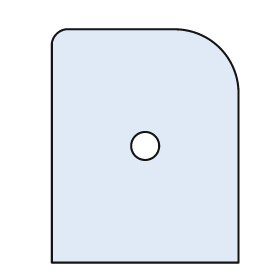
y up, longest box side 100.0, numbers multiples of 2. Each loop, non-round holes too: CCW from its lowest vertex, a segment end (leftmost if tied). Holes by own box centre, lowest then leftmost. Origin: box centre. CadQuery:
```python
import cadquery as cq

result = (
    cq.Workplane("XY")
    .moveTo(-40.0, -50.0)
    .lineTo(40.0, -50.0)
    .lineTo(40.0, 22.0)
    .threePointArc((32.0, 42.0), (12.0, 50.0))
    .lineTo(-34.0, 50.0)
    .threePointArc((-38.0, 48.0), (-40.0, 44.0))
    .close()
    .moveTo(0.0, 0.0)
    .circle(6.0)
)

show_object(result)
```